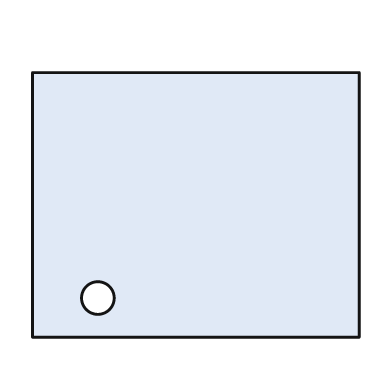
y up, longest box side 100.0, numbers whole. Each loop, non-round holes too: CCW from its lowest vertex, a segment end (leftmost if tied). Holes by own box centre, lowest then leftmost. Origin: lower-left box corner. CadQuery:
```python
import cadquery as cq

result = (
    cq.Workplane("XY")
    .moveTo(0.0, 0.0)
    .lineTo(100.0, 0.0)
    .lineTo(100.0, 81.0)
    .lineTo(0.0, 81.0)
    .close()
    .moveTo(20.0, 12.0)
    .circle(5.0)
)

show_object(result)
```